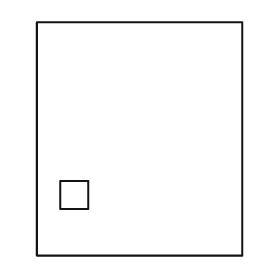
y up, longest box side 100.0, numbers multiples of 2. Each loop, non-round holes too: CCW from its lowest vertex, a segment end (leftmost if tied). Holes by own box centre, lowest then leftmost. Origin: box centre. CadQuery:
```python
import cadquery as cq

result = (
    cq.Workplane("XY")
    .moveTo(-44.0, -50.0)
    .lineTo(44.0, -50.0)
    .lineTo(44.0, 50.0)
    .lineTo(-44.0, 50.0)
    .close()
    .moveTo(-34.0, -30.0)
    .lineTo(-22.0, -30.0)
    .lineTo(-22.0, -18.0)
    .lineTo(-34.0, -18.0)
    .close()
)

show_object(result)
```